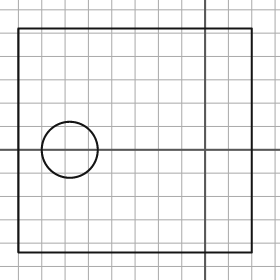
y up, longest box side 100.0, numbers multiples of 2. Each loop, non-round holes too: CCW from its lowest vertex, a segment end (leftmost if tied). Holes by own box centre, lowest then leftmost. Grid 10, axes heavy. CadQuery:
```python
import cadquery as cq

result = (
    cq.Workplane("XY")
    .moveTo(-80.0, -44.0)
    .lineTo(20.0, -44.0)
    .lineTo(20.0, 52.0)
    .lineTo(-80.0, 52.0)
    .close()
    .moveTo(-58.0, 0.0)
    .circle(12.0)
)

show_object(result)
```